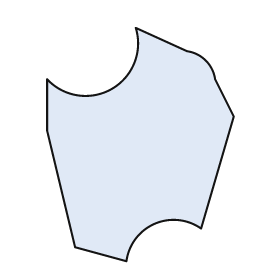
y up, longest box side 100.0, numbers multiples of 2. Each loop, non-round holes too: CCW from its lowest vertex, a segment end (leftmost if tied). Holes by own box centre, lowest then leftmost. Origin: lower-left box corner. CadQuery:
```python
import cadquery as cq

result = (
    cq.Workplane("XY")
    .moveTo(34.0, 0.0)
    .threePointArc((46.0, 16.0), (66.0, 14.0))
    .lineTo(80.0, 62.0)
    .lineTo(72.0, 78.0)
    .threePointArc((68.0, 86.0), (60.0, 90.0))
    .lineTo(38.0, 100.0)
    .threePointArc((28.0, 74.0), (0.0, 78.0))
    .lineTo(0.0, 56.0)
    .lineTo(12.0, 6.0)
    .close()
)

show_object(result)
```